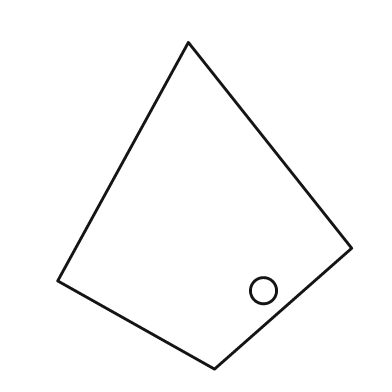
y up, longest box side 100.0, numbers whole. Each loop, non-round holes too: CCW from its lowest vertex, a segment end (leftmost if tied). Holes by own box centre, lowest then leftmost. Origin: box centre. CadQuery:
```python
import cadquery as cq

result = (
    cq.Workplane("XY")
    .moveTo(3.0, -50.0)
    .lineTo(45.0, -13.0)
    .lineTo(-5.0, 50.0)
    .lineTo(-45.0, -23.0)
    .close()
    .moveTo(18.0, -26.0)
    .circle(4.0)
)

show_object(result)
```